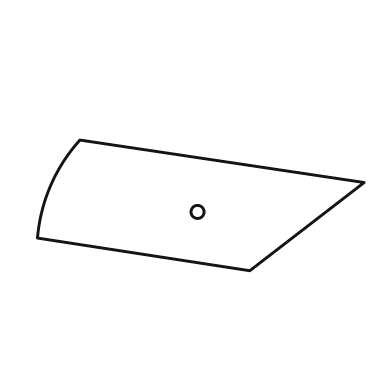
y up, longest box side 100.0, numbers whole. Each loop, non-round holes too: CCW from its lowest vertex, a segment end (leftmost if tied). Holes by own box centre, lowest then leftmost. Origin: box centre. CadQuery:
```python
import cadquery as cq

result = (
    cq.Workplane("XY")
    .moveTo(15.0, -20.0)
    .lineTo(50.0, 7.0)
    .lineTo(-37.0, 20.0)
    .threePointArc((-46.0, 6.0), (-50.0, -10.0))
    .close()
    .moveTo(-1.0, -2.0)
    .circle(2.0)
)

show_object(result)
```